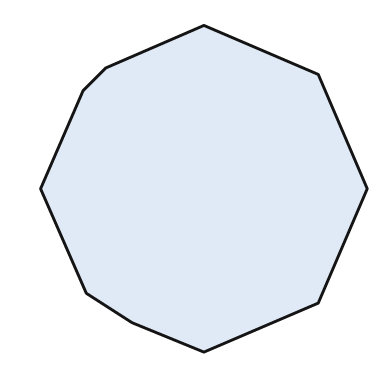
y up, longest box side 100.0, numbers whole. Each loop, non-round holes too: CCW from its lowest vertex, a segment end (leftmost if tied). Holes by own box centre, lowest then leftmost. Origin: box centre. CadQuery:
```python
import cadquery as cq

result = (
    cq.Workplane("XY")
    .moveTo(0.0, -50.0)
    .lineTo(35.0, -35.0)
    .lineTo(50.0, 0.0)
    .lineTo(35.0, 35.0)
    .lineTo(0.0, 50.0)
    .lineTo(-30.0, 37.0)
    .lineTo(-37.0, 30.0)
    .lineTo(-50.0, 0.0)
    .lineTo(-36.0, -32.0)
    .lineTo(-22.0, -41.0)
    .close()
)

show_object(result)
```